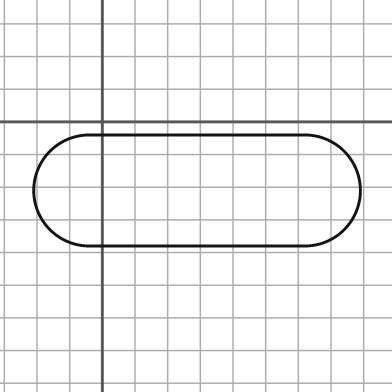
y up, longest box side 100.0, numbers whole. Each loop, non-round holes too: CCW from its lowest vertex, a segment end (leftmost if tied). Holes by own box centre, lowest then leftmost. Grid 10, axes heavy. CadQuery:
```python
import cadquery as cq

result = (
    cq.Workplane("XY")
    .moveTo(-4.0, -38.0)
    .lineTo(62.0, -38.0)
    .threePointArc((79.0, -21.0), (62.0, -4.0))
    .lineTo(-4.0, -4.0)
    .threePointArc((-21.0, -21.0), (-4.0, -38.0))
    .close()
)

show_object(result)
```